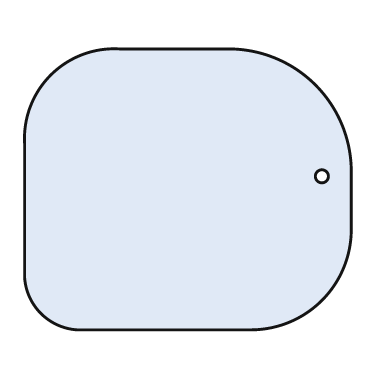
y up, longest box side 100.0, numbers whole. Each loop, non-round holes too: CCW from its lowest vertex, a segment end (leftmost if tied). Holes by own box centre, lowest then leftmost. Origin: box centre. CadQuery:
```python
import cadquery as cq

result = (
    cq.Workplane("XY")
    .moveTo(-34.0, -43.0)
    .lineTo(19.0, -43.0)
    .threePointArc((41.0, -34.0), (50.0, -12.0))
    .lineTo(50.0, 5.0)
    .threePointArc((39.0, 32.0), (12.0, 43.0))
    .lineTo(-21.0, 43.0)
    .threePointArc((-42.0, 35.0), (-50.0, 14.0))
    .lineTo(-50.0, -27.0)
    .threePointArc((-45.0, -38.0), (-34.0, -43.0))
    .close()
    .moveTo(41.0, 4.0)
    .circle(2.0)
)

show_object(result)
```